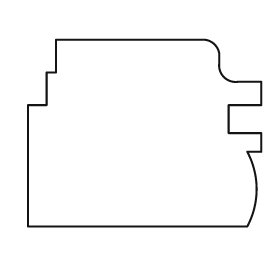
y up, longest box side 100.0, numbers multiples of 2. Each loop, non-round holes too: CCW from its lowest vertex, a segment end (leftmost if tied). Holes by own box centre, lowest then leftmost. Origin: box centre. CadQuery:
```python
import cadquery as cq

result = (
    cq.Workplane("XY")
    .moveTo(-50.0, -40.0)
    .lineTo(44.0, -40.0)
    .threePointArc((48.0, -24.0), (44.0, -8.0))
    .lineTo(50.0, -8.0)
    .lineTo(50.0, 0.0)
    .lineTo(36.0, 0.0)
    .lineTo(36.0, 12.0)
    .lineTo(50.0, 12.0)
    .lineTo(50.0, 22.0)
    .lineTo(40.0, 22.0)
    .threePointArc((34.0, 24.0), (32.0, 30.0))
    .lineTo(32.0, 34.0)
    .threePointArc((30.0, 38.0), (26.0, 40.0))
    .lineTo(-38.0, 40.0)
    .lineTo(-38.0, 26.0)
    .lineTo(-42.0, 26.0)
    .lineTo(-42.0, 12.0)
    .lineTo(-50.0, 12.0)
    .close()
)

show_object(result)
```